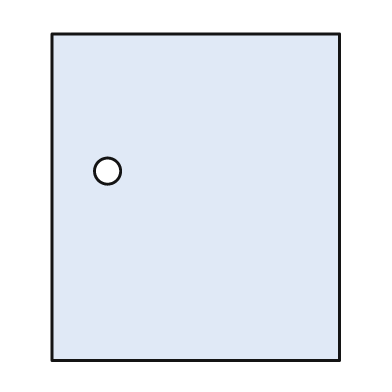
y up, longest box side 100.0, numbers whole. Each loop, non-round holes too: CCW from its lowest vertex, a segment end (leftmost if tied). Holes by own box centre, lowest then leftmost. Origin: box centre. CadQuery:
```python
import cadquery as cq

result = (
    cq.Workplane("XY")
    .moveTo(-44.0, -50.0)
    .lineTo(44.0, -50.0)
    .lineTo(44.0, 50.0)
    .lineTo(-44.0, 50.0)
    .close()
    .moveTo(-27.0, 8.0)
    .circle(4.0)
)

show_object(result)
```